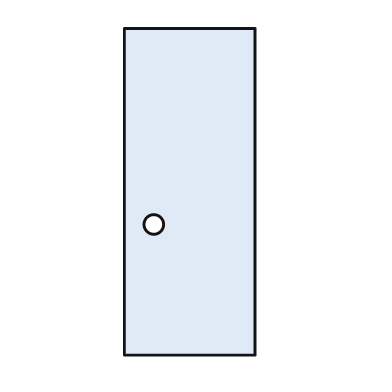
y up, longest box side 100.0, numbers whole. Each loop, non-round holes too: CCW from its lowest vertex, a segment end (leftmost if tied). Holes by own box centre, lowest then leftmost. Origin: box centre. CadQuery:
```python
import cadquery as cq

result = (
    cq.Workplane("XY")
    .moveTo(-20.0, -50.0)
    .lineTo(20.0, -50.0)
    .lineTo(20.0, 50.0)
    .lineTo(-20.0, 50.0)
    .close()
    .moveTo(-11.0, -10.0)
    .circle(3.0)
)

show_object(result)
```